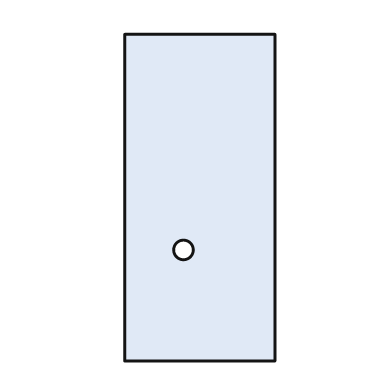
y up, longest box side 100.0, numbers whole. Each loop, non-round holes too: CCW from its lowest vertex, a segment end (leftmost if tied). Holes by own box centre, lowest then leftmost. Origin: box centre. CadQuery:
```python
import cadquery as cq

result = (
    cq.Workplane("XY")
    .moveTo(-23.0, -50.0)
    .lineTo(23.0, -50.0)
    .lineTo(23.0, 50.0)
    .lineTo(-23.0, 50.0)
    .close()
    .moveTo(-5.0, -16.0)
    .circle(3.0)
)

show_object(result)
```